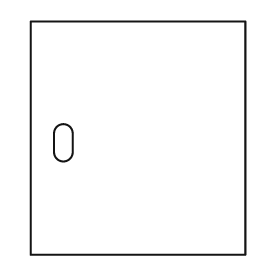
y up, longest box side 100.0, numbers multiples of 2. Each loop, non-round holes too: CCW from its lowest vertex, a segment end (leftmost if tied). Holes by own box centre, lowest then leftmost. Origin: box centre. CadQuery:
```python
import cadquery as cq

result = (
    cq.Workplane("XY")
    .moveTo(-46.0, -50.0)
    .lineTo(46.0, -50.0)
    .lineTo(46.0, 50.0)
    .lineTo(-46.0, 50.0)
    .close()
    .moveTo(-36.0, -6.0)
    .threePointArc((-32.0, -10.0), (-28.0, -6.0))
    .lineTo(-28.0, 2.0)
    .threePointArc((-32.0, 6.0), (-36.0, 2.0))
    .close()
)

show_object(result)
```